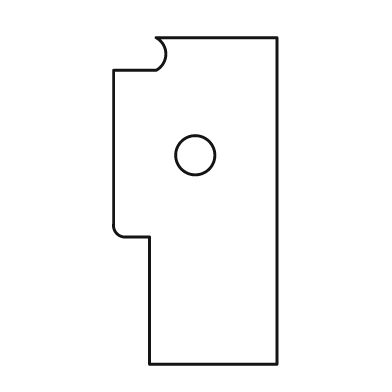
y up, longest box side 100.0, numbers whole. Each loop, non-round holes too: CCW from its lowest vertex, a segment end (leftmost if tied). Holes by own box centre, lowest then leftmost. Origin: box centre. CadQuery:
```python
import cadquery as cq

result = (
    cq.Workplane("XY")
    .moveTo(-14.0, -50.0)
    .lineTo(25.0, -50.0)
    .lineTo(25.0, 50.0)
    .lineTo(-12.0, 50.0)
    .threePointArc((-9.0, 45.0), (-12.0, 40.0))
    .lineTo(-25.0, 40.0)
    .lineTo(-25.0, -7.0)
    .threePointArc((-24.0, -10.0), (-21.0, -11.0))
    .lineTo(-14.0, -11.0)
    .close()
    .moveTo(0.0, 14.0)
    .circle(6.0)
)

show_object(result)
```